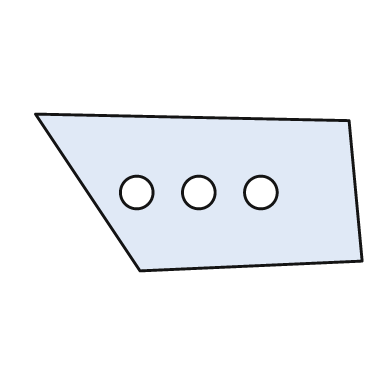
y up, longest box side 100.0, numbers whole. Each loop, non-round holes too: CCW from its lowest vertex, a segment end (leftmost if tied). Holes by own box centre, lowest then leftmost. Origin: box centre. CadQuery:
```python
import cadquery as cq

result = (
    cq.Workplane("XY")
    .moveTo(-18.0, -24.0)
    .lineTo(50.0, -21.0)
    .lineTo(46.0, 22.0)
    .lineTo(-50.0, 24.0)
    .close()
    .moveTo(-19.0, 0.0)
    .circle(5.0)
    .moveTo(0.0, 0.0)
    .circle(5.0)
    .moveTo(19.0, 0.0)
    .circle(5.0)
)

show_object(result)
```